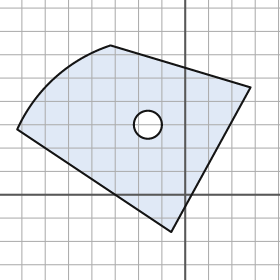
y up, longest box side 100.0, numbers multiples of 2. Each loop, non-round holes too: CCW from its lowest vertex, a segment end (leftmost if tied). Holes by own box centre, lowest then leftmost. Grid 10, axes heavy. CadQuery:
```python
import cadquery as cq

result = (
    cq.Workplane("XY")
    .moveTo(-6.0, -16.0)
    .lineTo(28.0, 46.0)
    .lineTo(-32.0, 64.0)
    .threePointArc((-56.0, 50.0), (-72.0, 28.0))
    .close()
    .moveTo(-16.0, 30.0)
    .circle(6.0)
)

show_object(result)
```